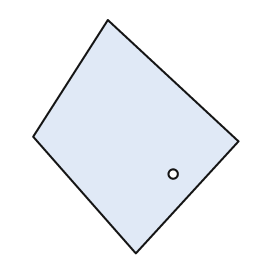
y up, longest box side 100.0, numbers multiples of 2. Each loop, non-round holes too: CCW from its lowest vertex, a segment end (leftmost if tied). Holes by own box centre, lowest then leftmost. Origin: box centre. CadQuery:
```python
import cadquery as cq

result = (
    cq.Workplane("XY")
    .moveTo(0.0, -50.0)
    .lineTo(44.0, -2.0)
    .lineTo(-12.0, 50.0)
    .lineTo(-44.0, 0.0)
    .close()
    .moveTo(16.0, -16.0)
    .circle(2.0)
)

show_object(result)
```